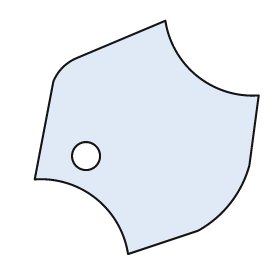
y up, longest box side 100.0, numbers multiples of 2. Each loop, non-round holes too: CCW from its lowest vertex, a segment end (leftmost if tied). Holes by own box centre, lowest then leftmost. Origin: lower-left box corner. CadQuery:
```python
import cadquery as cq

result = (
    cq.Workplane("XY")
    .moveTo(40.0, 0.0)
    .lineTo(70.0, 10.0)
    .threePointArc((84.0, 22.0), (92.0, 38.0))
    .lineTo(96.0, 68.0)
    .threePointArc((70.0, 76.0), (56.0, 100.0))
    .lineTo(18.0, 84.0)
    .threePointArc((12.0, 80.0), (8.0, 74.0))
    .lineTo(0.0, 32.0)
    .threePointArc((26.0, 24.0), (40.0, 0.0))
    .close()
    .moveTo(22.0, 42.0)
    .circle(6.0)
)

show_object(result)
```